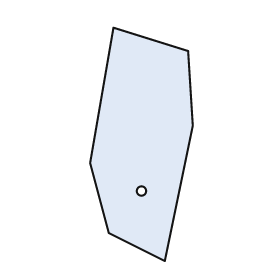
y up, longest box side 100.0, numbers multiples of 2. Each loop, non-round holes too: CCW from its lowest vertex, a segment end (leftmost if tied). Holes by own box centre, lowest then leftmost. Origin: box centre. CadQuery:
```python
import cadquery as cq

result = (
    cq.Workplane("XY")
    .moveTo(10.0, -50.0)
    .lineTo(22.0, 8.0)
    .lineTo(20.0, 40.0)
    .lineTo(-12.0, 50.0)
    .lineTo(-22.0, -8.0)
    .lineTo(-14.0, -38.0)
    .close()
    .moveTo(0.0, -20.0)
    .circle(2.0)
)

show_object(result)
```